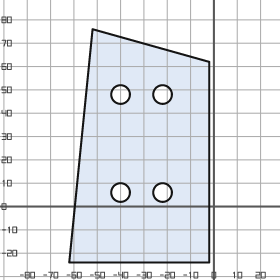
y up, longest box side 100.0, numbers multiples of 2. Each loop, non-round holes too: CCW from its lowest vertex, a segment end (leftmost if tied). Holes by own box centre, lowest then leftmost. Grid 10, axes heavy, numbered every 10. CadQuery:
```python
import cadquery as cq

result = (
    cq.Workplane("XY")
    .moveTo(-62.0, -24.0)
    .lineTo(-2.0, -24.0)
    .lineTo(-2.0, 62.0)
    .lineTo(-52.0, 76.0)
    .close()
    .moveTo(-40.0, 6.0)
    .circle(4.0)
    .moveTo(-22.0, 6.0)
    .circle(4.0)
    .moveTo(-40.0, 48.0)
    .circle(4.0)
    .moveTo(-22.0, 48.0)
    .circle(4.0)
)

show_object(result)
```